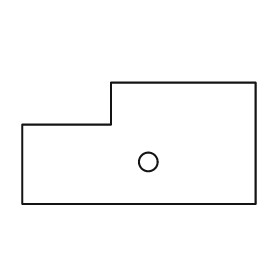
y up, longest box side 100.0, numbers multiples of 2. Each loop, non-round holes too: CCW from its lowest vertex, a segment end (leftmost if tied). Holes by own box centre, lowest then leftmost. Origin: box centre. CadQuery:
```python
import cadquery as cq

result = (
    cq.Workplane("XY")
    .moveTo(-50.0, -26.0)
    .lineTo(50.0, -26.0)
    .lineTo(50.0, 26.0)
    .lineTo(-12.0, 26.0)
    .lineTo(-12.0, 8.0)
    .lineTo(-50.0, 8.0)
    .close()
    .moveTo(4.0, -8.0)
    .circle(4.0)
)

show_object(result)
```